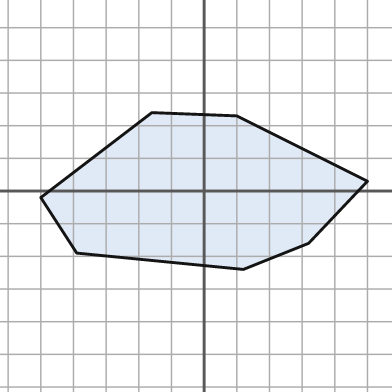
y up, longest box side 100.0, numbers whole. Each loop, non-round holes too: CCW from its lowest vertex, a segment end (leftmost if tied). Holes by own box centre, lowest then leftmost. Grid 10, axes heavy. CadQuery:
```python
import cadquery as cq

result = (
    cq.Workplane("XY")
    .moveTo(12.0, -24.0)
    .lineTo(32.0, -16.0)
    .lineTo(50.0, 3.0)
    .lineTo(10.0, 23.0)
    .lineTo(-16.0, 24.0)
    .lineTo(-50.0, -2.0)
    .lineTo(-39.0, -19.0)
    .close()
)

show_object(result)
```